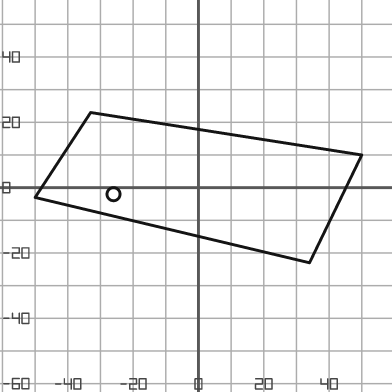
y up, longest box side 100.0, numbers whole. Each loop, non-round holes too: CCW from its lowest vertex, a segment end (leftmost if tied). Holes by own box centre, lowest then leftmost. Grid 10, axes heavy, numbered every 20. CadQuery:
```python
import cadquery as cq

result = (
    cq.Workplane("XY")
    .moveTo(34.0, -23.0)
    .lineTo(50.0, 10.0)
    .lineTo(-33.0, 23.0)
    .lineTo(-50.0, -3.0)
    .close()
    .moveTo(-26.0, -2.0)
    .circle(2.0)
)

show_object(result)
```